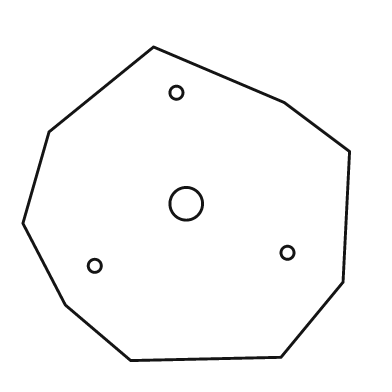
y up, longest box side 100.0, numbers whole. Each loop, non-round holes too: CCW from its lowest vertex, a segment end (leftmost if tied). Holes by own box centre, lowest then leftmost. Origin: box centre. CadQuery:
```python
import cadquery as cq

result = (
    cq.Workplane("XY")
    .moveTo(-17.0, -48.0)
    .lineTo(29.0, -47.0)
    .lineTo(48.0, -24.0)
    .lineTo(50.0, 16.0)
    .lineTo(30.0, 31.0)
    .lineTo(-10.0, 48.0)
    .lineTo(-42.0, 22.0)
    .lineTo(-50.0, -6.0)
    .lineTo(-37.0, -31.0)
    .close()
    .moveTo(-28.0, -19.0)
    .circle(2.0)
    .moveTo(31.0, -15.0)
    .circle(2.0)
    .moveTo(0.0, 0.0)
    .circle(5.0)
    .moveTo(-3.0, 34.0)
    .circle(2.0)
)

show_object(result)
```